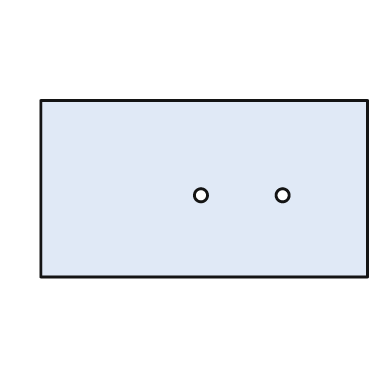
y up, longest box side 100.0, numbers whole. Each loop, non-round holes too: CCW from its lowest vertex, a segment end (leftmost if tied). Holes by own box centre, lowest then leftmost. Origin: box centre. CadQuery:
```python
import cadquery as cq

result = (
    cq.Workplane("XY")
    .moveTo(-50.0, -27.0)
    .lineTo(50.0, -27.0)
    .lineTo(50.0, 27.0)
    .lineTo(-50.0, 27.0)
    .close()
    .moveTo(-1.0, -2.0)
    .circle(2.0)
    .moveTo(24.0, -2.0)
    .circle(2.0)
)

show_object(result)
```